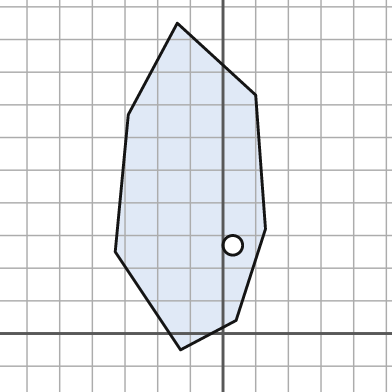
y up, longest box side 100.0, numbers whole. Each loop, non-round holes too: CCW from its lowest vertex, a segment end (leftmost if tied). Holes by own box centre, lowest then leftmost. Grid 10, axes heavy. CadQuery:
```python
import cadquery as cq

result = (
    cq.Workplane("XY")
    .moveTo(-13.0, -5.0)
    .lineTo(4.0, 4.0)
    .lineTo(13.0, 32.0)
    .lineTo(10.0, 73.0)
    .lineTo(-14.0, 95.0)
    .lineTo(-29.0, 67.0)
    .lineTo(-33.0, 25.0)
    .close()
    .moveTo(3.0, 27.0)
    .circle(3.0)
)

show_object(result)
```